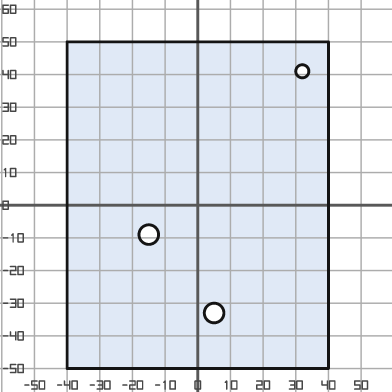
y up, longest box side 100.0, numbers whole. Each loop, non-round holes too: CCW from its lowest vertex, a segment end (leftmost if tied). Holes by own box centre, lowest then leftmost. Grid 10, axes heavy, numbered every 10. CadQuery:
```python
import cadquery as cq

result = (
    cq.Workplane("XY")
    .moveTo(-40.0, -50.0)
    .lineTo(40.0, -50.0)
    .lineTo(40.0, 50.0)
    .lineTo(-40.0, 50.0)
    .close()
    .moveTo(5.0, -33.0)
    .circle(3.0)
    .moveTo(-15.0, -9.0)
    .circle(3.0)
    .moveTo(32.0, 41.0)
    .circle(2.0)
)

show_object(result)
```